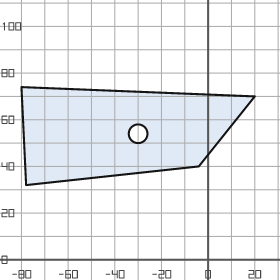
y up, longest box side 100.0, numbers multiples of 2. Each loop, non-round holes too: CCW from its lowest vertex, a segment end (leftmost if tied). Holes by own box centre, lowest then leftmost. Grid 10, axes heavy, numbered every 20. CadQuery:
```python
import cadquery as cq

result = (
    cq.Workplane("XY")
    .moveTo(-78.0, 32.0)
    .lineTo(-4.0, 40.0)
    .lineTo(20.0, 70.0)
    .lineTo(-80.0, 74.0)
    .close()
    .moveTo(-30.0, 54.0)
    .circle(4.0)
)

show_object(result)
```